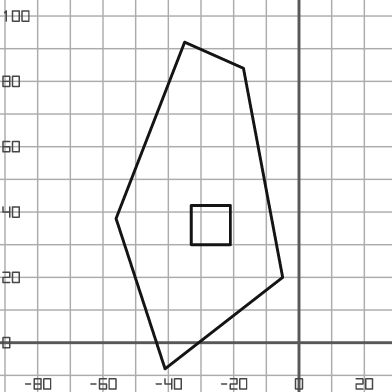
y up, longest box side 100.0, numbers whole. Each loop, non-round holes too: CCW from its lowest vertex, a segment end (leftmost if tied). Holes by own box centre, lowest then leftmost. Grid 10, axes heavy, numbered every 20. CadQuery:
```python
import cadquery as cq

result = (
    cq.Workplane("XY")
    .moveTo(-41.0, -8.0)
    .lineTo(-5.0, 20.0)
    .lineTo(-17.0, 84.0)
    .lineTo(-35.0, 92.0)
    .lineTo(-56.0, 38.0)
    .close()
    .moveTo(-33.0, 30.0)
    .lineTo(-21.0, 30.0)
    .lineTo(-21.0, 42.0)
    .lineTo(-33.0, 42.0)
    .close()
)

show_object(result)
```